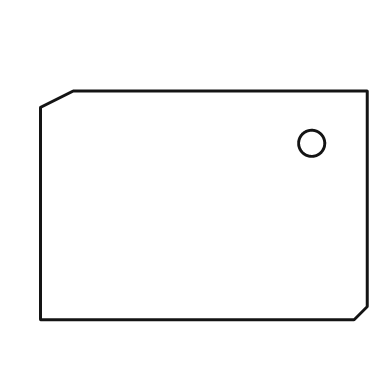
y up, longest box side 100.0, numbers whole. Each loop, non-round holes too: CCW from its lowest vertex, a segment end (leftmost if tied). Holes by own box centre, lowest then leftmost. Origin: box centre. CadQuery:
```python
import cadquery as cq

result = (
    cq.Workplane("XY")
    .moveTo(-50.0, -35.0)
    .lineTo(46.0, -35.0)
    .lineTo(50.0, -31.0)
    .lineTo(50.0, 35.0)
    .lineTo(-40.0, 35.0)
    .lineTo(-50.0, 30.0)
    .close()
    .moveTo(33.0, 19.0)
    .circle(4.0)
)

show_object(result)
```